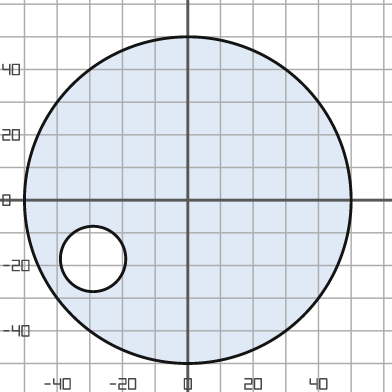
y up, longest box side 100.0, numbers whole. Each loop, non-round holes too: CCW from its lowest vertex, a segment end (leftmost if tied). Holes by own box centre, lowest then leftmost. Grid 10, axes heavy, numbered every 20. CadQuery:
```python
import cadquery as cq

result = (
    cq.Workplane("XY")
    .moveTo(0.0, 0.0)
    .circle(50.0)
    .moveTo(-29.0, -18.0)
    .circle(10.0)
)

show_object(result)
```